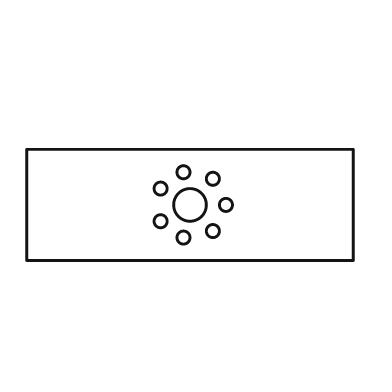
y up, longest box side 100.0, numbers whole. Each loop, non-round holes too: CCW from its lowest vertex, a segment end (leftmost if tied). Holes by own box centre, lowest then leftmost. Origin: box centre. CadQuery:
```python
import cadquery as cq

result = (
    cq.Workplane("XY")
    .moveTo(-50.0, -17.0)
    .lineTo(50.0, -17.0)
    .lineTo(50.0, 17.0)
    .lineTo(-50.0, 17.0)
    .close()
    .moveTo(-2.0, -10.0)
    .circle(2.0)
    .moveTo(7.0, -8.0)
    .circle(2.0)
    .moveTo(-9.0, -5.0)
    .circle(2.0)
    .moveTo(0.0, 0.0)
    .circle(5.0)
    .moveTo(11.0, 0.0)
    .circle(2.0)
    .moveTo(-9.0, 5.0)
    .circle(2.0)
    .moveTo(7.0, 8.0)
    .circle(2.0)
    .moveTo(-2.0, 10.0)
    .circle(2.0)
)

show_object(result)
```